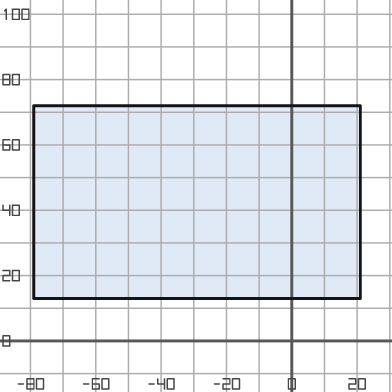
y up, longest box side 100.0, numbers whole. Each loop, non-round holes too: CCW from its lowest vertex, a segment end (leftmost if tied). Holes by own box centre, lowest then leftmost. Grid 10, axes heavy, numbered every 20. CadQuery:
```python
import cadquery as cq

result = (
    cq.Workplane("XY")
    .moveTo(-79.0, 13.0)
    .lineTo(21.0, 13.0)
    .lineTo(21.0, 72.0)
    .lineTo(-79.0, 72.0)
    .close()
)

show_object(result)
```